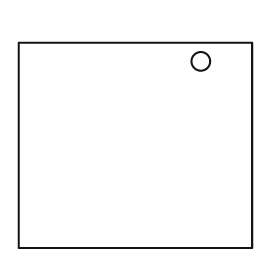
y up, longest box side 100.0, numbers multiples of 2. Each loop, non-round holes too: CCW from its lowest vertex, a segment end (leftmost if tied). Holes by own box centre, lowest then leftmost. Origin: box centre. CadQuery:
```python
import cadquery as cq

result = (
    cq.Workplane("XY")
    .moveTo(-50.0, -44.0)
    .lineTo(50.0, -44.0)
    .lineTo(50.0, 44.0)
    .lineTo(-50.0, 44.0)
    .close()
    .moveTo(28.0, 36.0)
    .circle(4.0)
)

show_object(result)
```